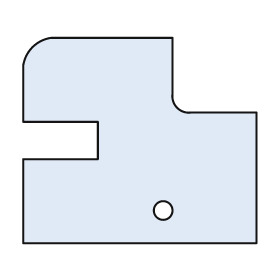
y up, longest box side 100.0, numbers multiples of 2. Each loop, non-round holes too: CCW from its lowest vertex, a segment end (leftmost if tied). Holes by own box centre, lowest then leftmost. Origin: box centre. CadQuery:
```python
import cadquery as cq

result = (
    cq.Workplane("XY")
    .moveTo(-50.0, -44.0)
    .lineTo(50.0, -44.0)
    .lineTo(50.0, 12.0)
    .lineTo(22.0, 12.0)
    .threePointArc((16.0, 14.0), (14.0, 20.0))
    .lineTo(14.0, 44.0)
    .lineTo(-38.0, 44.0)
    .threePointArc((-46.0, 40.0), (-50.0, 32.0))
    .lineTo(-50.0, 8.0)
    .lineTo(-18.0, 8.0)
    .lineTo(-18.0, -8.0)
    .lineTo(-50.0, -8.0)
    .close()
    .moveTo(10.0, -30.0)
    .circle(4.0)
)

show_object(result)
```